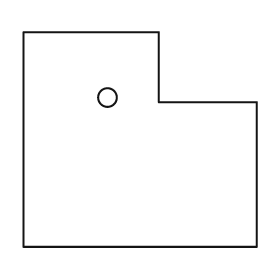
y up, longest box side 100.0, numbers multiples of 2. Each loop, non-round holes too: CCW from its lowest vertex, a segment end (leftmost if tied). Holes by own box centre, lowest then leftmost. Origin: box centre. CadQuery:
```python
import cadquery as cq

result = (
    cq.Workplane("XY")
    .moveTo(-50.0, -46.0)
    .lineTo(50.0, -46.0)
    .lineTo(50.0, 16.0)
    .lineTo(8.0, 16.0)
    .lineTo(8.0, 46.0)
    .lineTo(-50.0, 46.0)
    .close()
    .moveTo(-14.0, 18.0)
    .circle(4.0)
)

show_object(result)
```